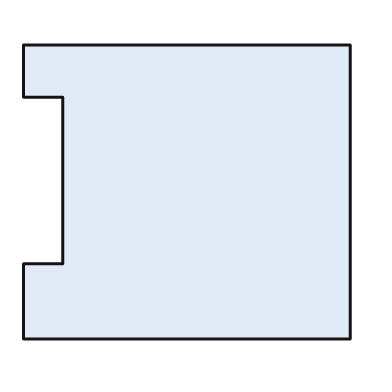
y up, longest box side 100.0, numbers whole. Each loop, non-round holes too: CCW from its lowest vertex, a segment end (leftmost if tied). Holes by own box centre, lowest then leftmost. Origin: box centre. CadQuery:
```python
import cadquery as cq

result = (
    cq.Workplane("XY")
    .moveTo(-50.0, -45.0)
    .lineTo(50.0, -45.0)
    .lineTo(50.0, 45.0)
    .lineTo(-50.0, 45.0)
    .lineTo(-50.0, 29.0)
    .lineTo(-38.0, 29.0)
    .lineTo(-38.0, -22.0)
    .lineTo(-50.0, -22.0)
    .close()
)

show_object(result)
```